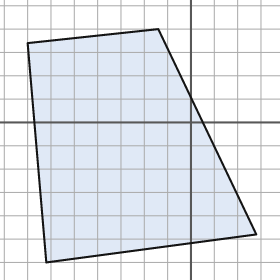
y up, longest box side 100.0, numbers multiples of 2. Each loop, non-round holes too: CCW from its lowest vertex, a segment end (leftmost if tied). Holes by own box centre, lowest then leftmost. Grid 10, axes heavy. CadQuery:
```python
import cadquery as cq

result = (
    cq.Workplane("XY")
    .moveTo(-62.0, -60.0)
    .lineTo(28.0, -48.0)
    .lineTo(-14.0, 40.0)
    .lineTo(-70.0, 34.0)
    .close()
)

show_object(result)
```